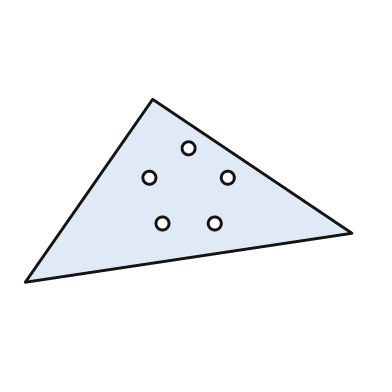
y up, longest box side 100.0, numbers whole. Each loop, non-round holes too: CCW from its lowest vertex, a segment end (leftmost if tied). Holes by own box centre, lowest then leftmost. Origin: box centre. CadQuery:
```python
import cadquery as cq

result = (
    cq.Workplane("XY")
    .moveTo(-50.0, -28.0)
    .lineTo(50.0, -13.0)
    .lineTo(-11.0, 28.0)
    .close()
    .moveTo(-8.0, -10.0)
    .circle(2.0)
    .moveTo(8.0, -10.0)
    .circle(2.0)
    .moveTo(-12.0, 4.0)
    .circle(2.0)
    .moveTo(12.0, 4.0)
    .circle(2.0)
    .moveTo(0.0, 13.0)
    .circle(2.0)
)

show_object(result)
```